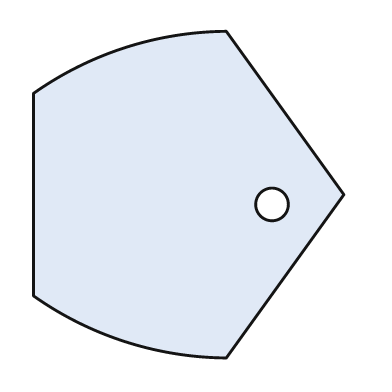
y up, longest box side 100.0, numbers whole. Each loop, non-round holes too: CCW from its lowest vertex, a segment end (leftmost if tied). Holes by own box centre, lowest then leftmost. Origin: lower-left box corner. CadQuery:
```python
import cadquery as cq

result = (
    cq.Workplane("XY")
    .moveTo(59.0, 0.0)
    .lineTo(95.0, 50.0)
    .lineTo(59.0, 100.0)
    .threePointArc((28.0, 95.0), (0.0, 81.0))
    .lineTo(0.0, 19.0)
    .threePointArc((28.0, 5.0), (59.0, 0.0))
    .close()
    .moveTo(73.0, 47.0)
    .circle(5.0)
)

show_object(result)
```